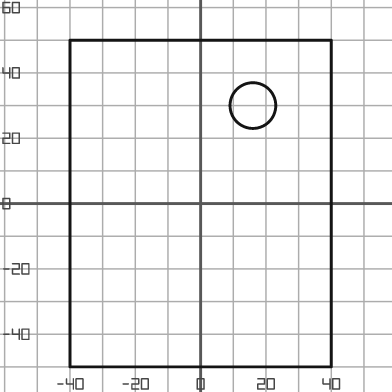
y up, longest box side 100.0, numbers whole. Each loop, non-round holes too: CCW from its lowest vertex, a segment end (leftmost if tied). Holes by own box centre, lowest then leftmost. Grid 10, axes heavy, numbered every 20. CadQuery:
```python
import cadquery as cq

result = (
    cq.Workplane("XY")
    .moveTo(-40.0, -50.0)
    .lineTo(40.0, -50.0)
    .lineTo(40.0, 50.0)
    .lineTo(-40.0, 50.0)
    .close()
    .moveTo(16.0, 30.0)
    .circle(7.0)
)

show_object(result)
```